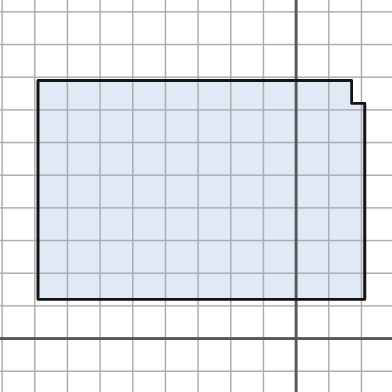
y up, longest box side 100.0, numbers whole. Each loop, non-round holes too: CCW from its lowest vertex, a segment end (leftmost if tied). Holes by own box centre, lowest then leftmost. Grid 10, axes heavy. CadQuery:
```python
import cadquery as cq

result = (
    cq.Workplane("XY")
    .moveTo(-79.0, 12.0)
    .lineTo(21.0, 12.0)
    .lineTo(21.0, 72.0)
    .lineTo(17.0, 72.0)
    .lineTo(17.0, 79.0)
    .lineTo(-79.0, 79.0)
    .close()
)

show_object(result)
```